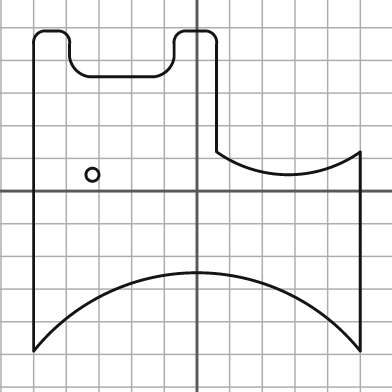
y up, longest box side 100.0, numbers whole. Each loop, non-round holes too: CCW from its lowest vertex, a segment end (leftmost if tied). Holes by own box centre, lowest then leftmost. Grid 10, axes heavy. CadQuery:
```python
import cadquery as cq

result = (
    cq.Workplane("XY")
    .moveTo(-50.0, -49.0)
    .threePointArc((0.0, -25.0), (50.0, -49.0))
    .lineTo(50.0, 12.0)
    .threePointArc((28.0, 5.0), (6.0, 12.0))
    .lineTo(6.0, 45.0)
    .threePointArc((5.0, 48.0), (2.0, 49.0))
    .lineTo(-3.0, 49.0)
    .threePointArc((-6.0, 48.0), (-7.0, 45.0))
    .lineTo(-7.0, 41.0)
    .threePointArc((-9.0, 37.0), (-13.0, 35.0))
    .lineTo(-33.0, 35.0)
    .threePointArc((-37.0, 37.0), (-39.0, 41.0))
    .lineTo(-39.0, 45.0)
    .threePointArc((-40.0, 48.0), (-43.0, 49.0))
    .lineTo(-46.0, 49.0)
    .threePointArc((-49.0, 48.0), (-50.0, 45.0))
    .close()
    .moveTo(-32.0, 5.0)
    .circle(2.0)
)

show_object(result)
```